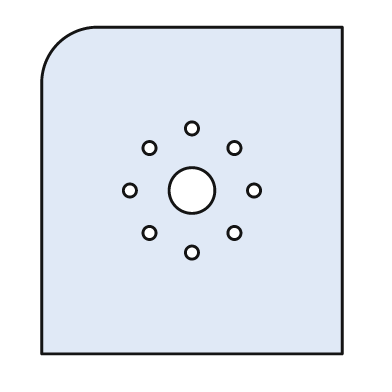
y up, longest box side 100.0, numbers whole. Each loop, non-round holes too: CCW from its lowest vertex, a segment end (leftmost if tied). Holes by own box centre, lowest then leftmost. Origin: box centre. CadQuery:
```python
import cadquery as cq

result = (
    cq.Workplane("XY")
    .moveTo(-46.0, -50.0)
    .lineTo(46.0, -50.0)
    .lineTo(46.0, 50.0)
    .lineTo(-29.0, 50.0)
    .threePointArc((-41.0, 45.0), (-46.0, 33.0))
    .close()
    .moveTo(0.0, -19.0)
    .circle(2.0)
    .moveTo(-13.0, -13.0)
    .circle(2.0)
    .moveTo(13.0, -13.0)
    .circle(2.0)
    .moveTo(-19.0, 0.0)
    .circle(2.0)
    .moveTo(0.0, 0.0)
    .circle(7.0)
    .moveTo(19.0, 0.0)
    .circle(2.0)
    .moveTo(-13.0, 13.0)
    .circle(2.0)
    .moveTo(13.0, 13.0)
    .circle(2.0)
    .moveTo(0.0, 19.0)
    .circle(2.0)
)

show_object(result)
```